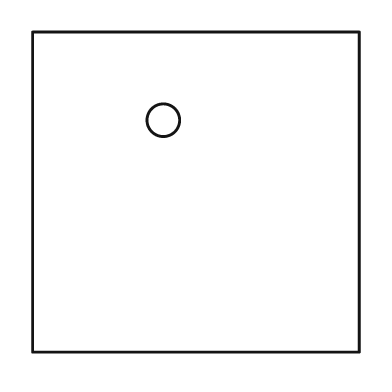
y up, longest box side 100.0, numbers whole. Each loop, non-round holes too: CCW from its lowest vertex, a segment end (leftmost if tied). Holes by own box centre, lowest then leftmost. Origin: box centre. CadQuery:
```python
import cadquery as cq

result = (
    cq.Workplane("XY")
    .moveTo(-50.0, -49.0)
    .lineTo(50.0, -49.0)
    .lineTo(50.0, 49.0)
    .lineTo(-50.0, 49.0)
    .close()
    .moveTo(-10.0, 22.0)
    .circle(5.0)
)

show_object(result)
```